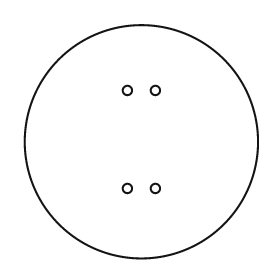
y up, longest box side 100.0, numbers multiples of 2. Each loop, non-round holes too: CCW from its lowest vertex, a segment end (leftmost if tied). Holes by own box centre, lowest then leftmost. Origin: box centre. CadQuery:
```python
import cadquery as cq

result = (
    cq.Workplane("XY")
    .moveTo(0.0, 0.0)
    .circle(50.0)
    .moveTo(-6.0, -20.0)
    .circle(2.0)
    .moveTo(6.0, -20.0)
    .circle(2.0)
    .moveTo(-6.0, 22.0)
    .circle(2.0)
    .moveTo(6.0, 22.0)
    .circle(2.0)
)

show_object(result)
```